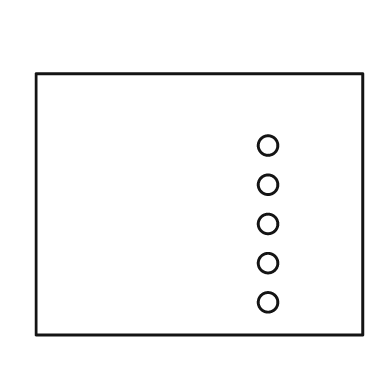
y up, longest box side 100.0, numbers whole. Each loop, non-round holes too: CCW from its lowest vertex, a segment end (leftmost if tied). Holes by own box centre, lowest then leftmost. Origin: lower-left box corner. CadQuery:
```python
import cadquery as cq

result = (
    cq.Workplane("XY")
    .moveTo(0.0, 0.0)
    .lineTo(100.0, 0.0)
    .lineTo(100.0, 80.0)
    .lineTo(0.0, 80.0)
    .close()
    .moveTo(71.0, 10.0)
    .circle(3.0)
    .moveTo(71.0, 22.0)
    .circle(3.0)
    .moveTo(71.0, 34.0)
    .circle(3.0)
    .moveTo(71.0, 46.0)
    .circle(3.0)
    .moveTo(71.0, 58.0)
    .circle(3.0)
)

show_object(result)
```